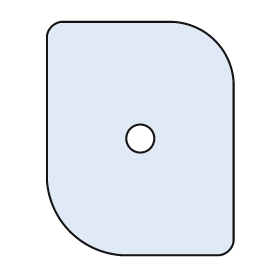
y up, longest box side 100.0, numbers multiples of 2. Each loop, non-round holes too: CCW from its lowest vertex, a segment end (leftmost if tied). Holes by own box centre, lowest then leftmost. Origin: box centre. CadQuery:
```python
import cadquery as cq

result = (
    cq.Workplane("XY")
    .moveTo(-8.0, -50.0)
    .lineTo(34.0, -50.0)
    .threePointArc((38.0, -48.0), (40.0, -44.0))
    .lineTo(40.0, 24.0)
    .threePointArc((32.0, 42.0), (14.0, 50.0))
    .lineTo(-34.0, 50.0)
    .threePointArc((-38.0, 48.0), (-40.0, 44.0))
    .lineTo(-40.0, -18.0)
    .threePointArc((-30.0, -40.0), (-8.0, -50.0))
    .close()
    .moveTo(0.0, 0.0)
    .circle(6.0)
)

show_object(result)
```